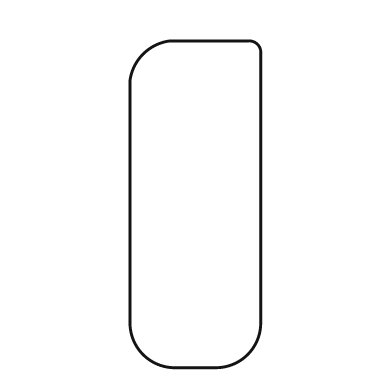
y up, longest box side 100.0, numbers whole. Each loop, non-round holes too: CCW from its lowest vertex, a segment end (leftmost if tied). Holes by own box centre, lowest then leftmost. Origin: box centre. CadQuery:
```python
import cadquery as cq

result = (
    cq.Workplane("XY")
    .moveTo(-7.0, -50.0)
    .lineTo(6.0, -50.0)
    .threePointArc((16.0, -46.0), (20.0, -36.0))
    .lineTo(20.0, 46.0)
    .threePointArc((19.0, 49.0), (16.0, 50.0))
    .lineTo(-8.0, 50.0)
    .threePointArc((-16.0, 46.0), (-20.0, 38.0))
    .lineTo(-20.0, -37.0)
    .threePointArc((-16.0, -46.0), (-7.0, -50.0))
    .close()
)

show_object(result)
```